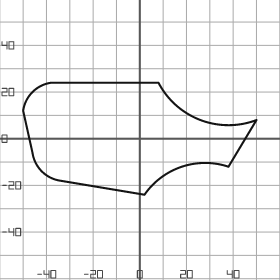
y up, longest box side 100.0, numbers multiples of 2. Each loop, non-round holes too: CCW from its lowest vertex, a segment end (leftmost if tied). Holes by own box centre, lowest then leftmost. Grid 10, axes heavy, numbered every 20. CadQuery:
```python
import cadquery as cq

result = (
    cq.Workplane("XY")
    .moveTo(2.0, -24.0)
    .threePointArc((18.0, -12.0), (38.0, -12.0))
    .lineTo(50.0, 8.0)
    .threePointArc((26.0, 8.0), (8.0, 24.0))
    .lineTo(-38.0, 24.0)
    .threePointArc((-46.0, 20.0), (-50.0, 12.0))
    .lineTo(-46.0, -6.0)
    .threePointArc((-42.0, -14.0), (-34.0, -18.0))
    .close()
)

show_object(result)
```